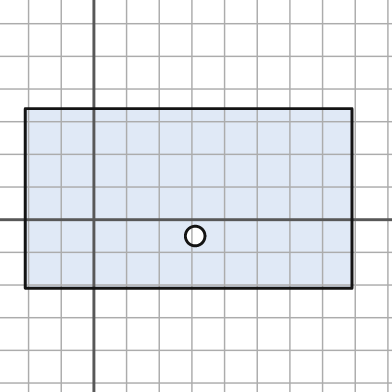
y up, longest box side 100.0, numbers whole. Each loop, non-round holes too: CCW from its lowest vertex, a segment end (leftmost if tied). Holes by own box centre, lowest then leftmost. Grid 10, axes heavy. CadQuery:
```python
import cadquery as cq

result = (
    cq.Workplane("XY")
    .moveTo(-21.0, -21.0)
    .lineTo(79.0, -21.0)
    .lineTo(79.0, 34.0)
    .lineTo(-21.0, 34.0)
    .close()
    .moveTo(31.0, -5.0)
    .circle(3.0)
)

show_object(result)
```